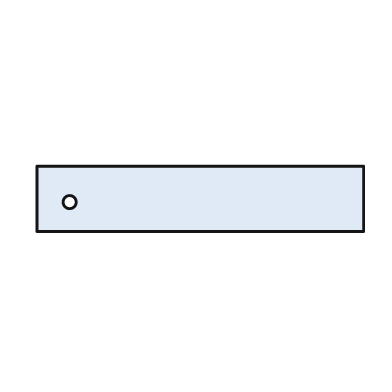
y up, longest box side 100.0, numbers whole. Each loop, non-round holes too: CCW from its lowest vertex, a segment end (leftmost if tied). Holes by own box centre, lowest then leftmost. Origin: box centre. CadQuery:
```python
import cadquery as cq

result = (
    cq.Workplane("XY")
    .moveTo(-50.0, -10.0)
    .lineTo(50.0, -10.0)
    .lineTo(50.0, 10.0)
    .lineTo(-50.0, 10.0)
    .close()
    .moveTo(-40.0, -1.0)
    .circle(2.0)
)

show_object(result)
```